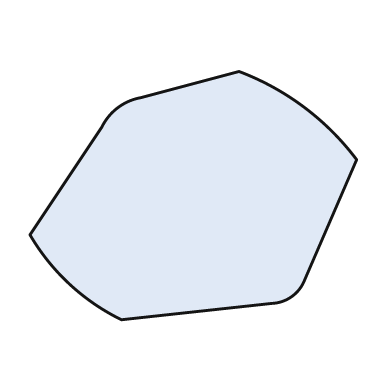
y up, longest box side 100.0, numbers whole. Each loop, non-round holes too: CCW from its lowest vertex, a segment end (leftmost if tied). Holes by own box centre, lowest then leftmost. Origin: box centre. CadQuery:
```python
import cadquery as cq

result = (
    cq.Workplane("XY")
    .moveTo(-22.0, -38.0)
    .lineTo(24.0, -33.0)
    .threePointArc((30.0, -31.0), (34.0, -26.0))
    .lineTo(50.0, 11.0)
    .threePointArc((34.0, 27.0), (14.0, 38.0))
    .lineTo(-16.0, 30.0)
    .threePointArc((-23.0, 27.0), (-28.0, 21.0))
    .lineTo(-50.0, -12.0)
    .threePointArc((-38.0, -27.0), (-22.0, -38.0))
    .close()
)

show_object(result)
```